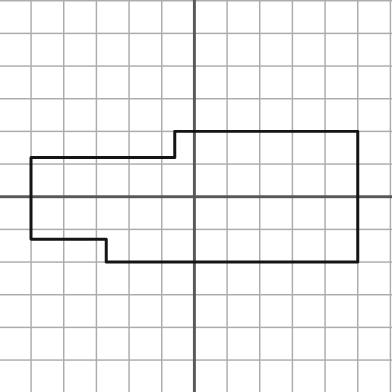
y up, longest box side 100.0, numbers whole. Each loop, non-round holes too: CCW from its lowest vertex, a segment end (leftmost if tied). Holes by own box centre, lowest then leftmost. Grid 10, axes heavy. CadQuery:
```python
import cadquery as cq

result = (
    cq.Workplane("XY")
    .moveTo(-27.0, -20.0)
    .lineTo(50.0, -20.0)
    .lineTo(50.0, 20.0)
    .lineTo(-6.0, 20.0)
    .lineTo(-6.0, 12.0)
    .lineTo(-50.0, 12.0)
    .lineTo(-50.0, -13.0)
    .lineTo(-27.0, -13.0)
    .close()
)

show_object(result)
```